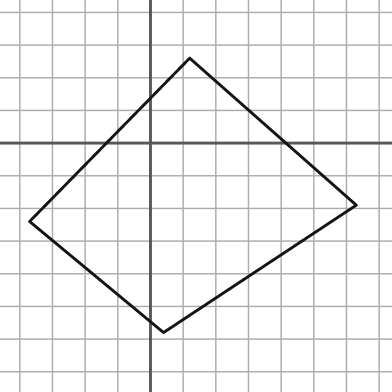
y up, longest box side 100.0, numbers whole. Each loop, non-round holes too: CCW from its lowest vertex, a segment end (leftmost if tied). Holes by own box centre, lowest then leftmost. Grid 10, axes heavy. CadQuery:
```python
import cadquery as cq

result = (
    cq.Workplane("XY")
    .moveTo(4.0, -58.0)
    .lineTo(63.0, -19.0)
    .lineTo(12.0, 26.0)
    .lineTo(-37.0, -24.0)
    .close()
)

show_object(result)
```